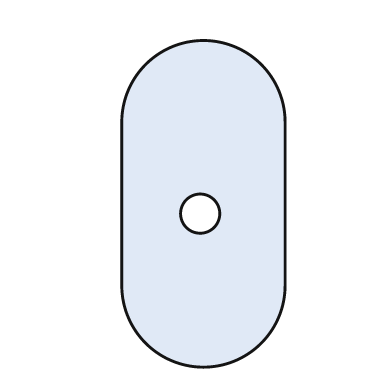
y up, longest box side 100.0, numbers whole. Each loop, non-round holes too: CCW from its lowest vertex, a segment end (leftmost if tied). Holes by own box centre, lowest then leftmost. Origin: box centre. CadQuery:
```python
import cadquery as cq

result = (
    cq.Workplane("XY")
    .moveTo(-25.0, -25.0)
    .threePointArc((0.0, -50.0), (25.0, -25.0))
    .lineTo(25.0, 25.0)
    .threePointArc((0.0, 50.0), (-25.0, 25.0))
    .close()
    .moveTo(-1.0, -3.0)
    .circle(6.0)
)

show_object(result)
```